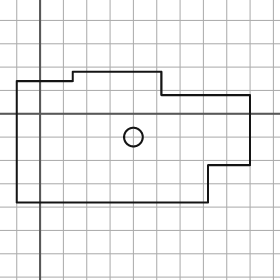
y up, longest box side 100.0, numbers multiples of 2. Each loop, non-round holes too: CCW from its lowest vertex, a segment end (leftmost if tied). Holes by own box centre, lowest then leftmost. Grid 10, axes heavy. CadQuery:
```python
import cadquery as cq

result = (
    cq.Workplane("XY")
    .moveTo(-10.0, -38.0)
    .lineTo(72.0, -38.0)
    .lineTo(72.0, -22.0)
    .lineTo(90.0, -22.0)
    .lineTo(90.0, 8.0)
    .lineTo(52.0, 8.0)
    .lineTo(52.0, 18.0)
    .lineTo(14.0, 18.0)
    .lineTo(14.0, 14.0)
    .lineTo(-10.0, 14.0)
    .close()
    .moveTo(40.0, -10.0)
    .circle(4.0)
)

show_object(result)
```